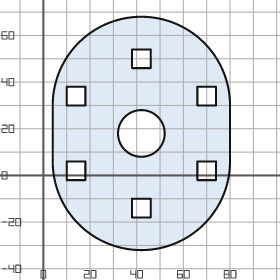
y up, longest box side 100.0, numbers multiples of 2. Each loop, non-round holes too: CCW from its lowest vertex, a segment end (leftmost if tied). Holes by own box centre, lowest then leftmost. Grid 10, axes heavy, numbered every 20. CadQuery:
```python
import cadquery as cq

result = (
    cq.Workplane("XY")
    .moveTo(4.0, 6.0)
    .threePointArc((42.0, -32.0), (80.0, 6.0))
    .lineTo(80.0, 30.0)
    .threePointArc((42.0, 68.0), (4.0, 30.0))
    .close()
    .moveTo(38.0, -18.0)
    .lineTo(46.0, -18.0)
    .lineTo(46.0, -10.0)
    .lineTo(38.0, -10.0)
    .close()
    .moveTo(10.0, -2.0)
    .lineTo(18.0, -2.0)
    .lineTo(18.0, 6.0)
    .lineTo(10.0, 6.0)
    .close()
    .moveTo(66.0, -2.0)
    .lineTo(74.0, -2.0)
    .lineTo(74.0, 6.0)
    .lineTo(66.0, 6.0)
    .close()
    .moveTo(42.0, 18.0)
    .circle(10.0)
    .moveTo(10.0, 30.0)
    .lineTo(18.0, 30.0)
    .lineTo(18.0, 38.0)
    .lineTo(10.0, 38.0)
    .close()
    .moveTo(66.0, 30.0)
    .lineTo(74.0, 30.0)
    .lineTo(74.0, 38.0)
    .lineTo(66.0, 38.0)
    .close()
    .moveTo(38.0, 46.0)
    .lineTo(46.0, 46.0)
    .lineTo(46.0, 54.0)
    .lineTo(38.0, 54.0)
    .close()
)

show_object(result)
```